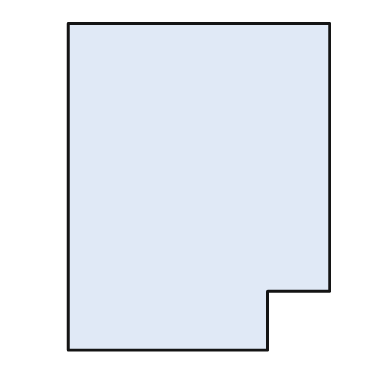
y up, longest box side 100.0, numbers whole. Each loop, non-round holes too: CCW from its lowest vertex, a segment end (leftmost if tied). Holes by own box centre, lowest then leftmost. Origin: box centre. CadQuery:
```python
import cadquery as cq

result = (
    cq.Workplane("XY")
    .moveTo(-40.0, -50.0)
    .lineTo(21.0, -50.0)
    .lineTo(21.0, -32.0)
    .lineTo(40.0, -32.0)
    .lineTo(40.0, 50.0)
    .lineTo(-40.0, 50.0)
    .close()
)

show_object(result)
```